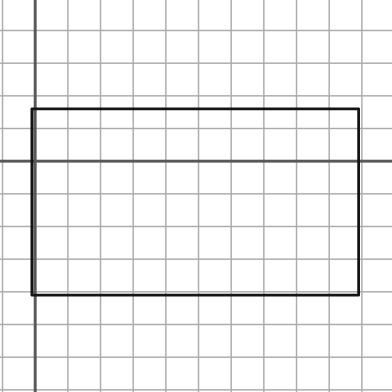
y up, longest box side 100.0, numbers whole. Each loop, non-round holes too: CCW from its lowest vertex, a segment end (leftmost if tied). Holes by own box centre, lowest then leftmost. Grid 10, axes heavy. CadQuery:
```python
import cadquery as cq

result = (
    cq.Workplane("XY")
    .moveTo(-1.0, -41.0)
    .lineTo(99.0, -41.0)
    .lineTo(99.0, 16.0)
    .lineTo(-1.0, 16.0)
    .close()
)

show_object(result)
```